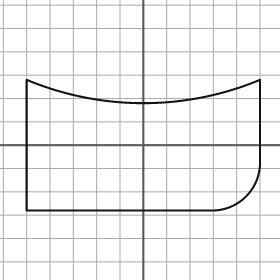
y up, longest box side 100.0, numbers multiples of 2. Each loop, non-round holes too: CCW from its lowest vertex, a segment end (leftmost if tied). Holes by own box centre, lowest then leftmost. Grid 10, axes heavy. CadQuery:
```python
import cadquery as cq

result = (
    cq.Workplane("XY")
    .moveTo(-50.0, -28.0)
    .lineTo(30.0, -28.0)
    .threePointArc((44.0, -22.0), (50.0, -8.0))
    .lineTo(50.0, 28.0)
    .threePointArc((0.0, 18.0), (-50.0, 28.0))
    .close()
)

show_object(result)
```